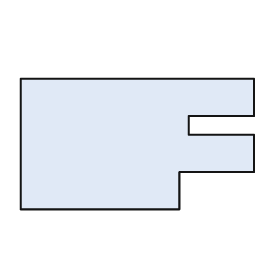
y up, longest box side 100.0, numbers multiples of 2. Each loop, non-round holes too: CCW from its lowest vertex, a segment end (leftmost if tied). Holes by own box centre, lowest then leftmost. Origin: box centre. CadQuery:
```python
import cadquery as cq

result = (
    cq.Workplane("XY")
    .moveTo(-50.0, -28.0)
    .lineTo(18.0, -28.0)
    .lineTo(18.0, -12.0)
    .lineTo(50.0, -12.0)
    .lineTo(50.0, 4.0)
    .lineTo(22.0, 4.0)
    .lineTo(22.0, 12.0)
    .lineTo(50.0, 12.0)
    .lineTo(50.0, 28.0)
    .lineTo(-50.0, 28.0)
    .close()
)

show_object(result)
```